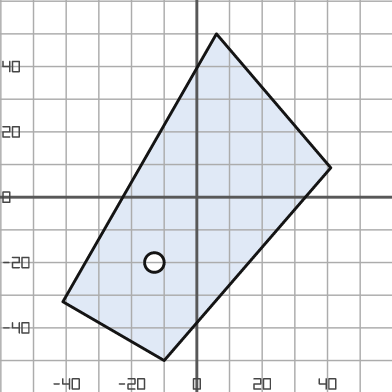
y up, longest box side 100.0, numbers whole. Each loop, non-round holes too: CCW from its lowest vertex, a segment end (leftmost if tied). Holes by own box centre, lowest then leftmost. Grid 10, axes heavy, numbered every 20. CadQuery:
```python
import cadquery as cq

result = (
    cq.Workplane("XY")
    .moveTo(-10.0, -50.0)
    .lineTo(41.0, 9.0)
    .lineTo(6.0, 50.0)
    .lineTo(-41.0, -32.0)
    .close()
    .moveTo(-13.0, -20.0)
    .circle(3.0)
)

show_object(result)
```